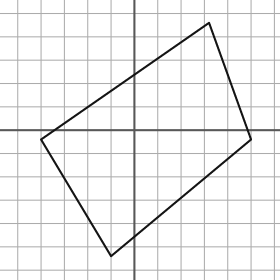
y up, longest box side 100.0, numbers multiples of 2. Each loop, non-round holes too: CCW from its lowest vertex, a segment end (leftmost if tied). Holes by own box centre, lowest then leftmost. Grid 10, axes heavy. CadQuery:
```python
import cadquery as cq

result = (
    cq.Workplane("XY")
    .moveTo(-10.0, -54.0)
    .lineTo(50.0, -4.0)
    .lineTo(32.0, 46.0)
    .lineTo(-40.0, -4.0)
    .close()
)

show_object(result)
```